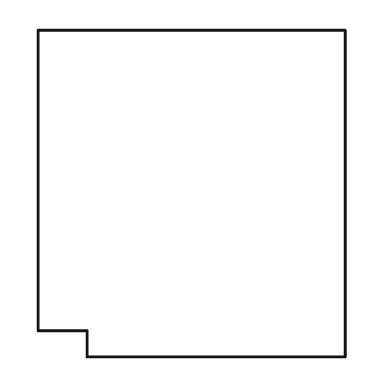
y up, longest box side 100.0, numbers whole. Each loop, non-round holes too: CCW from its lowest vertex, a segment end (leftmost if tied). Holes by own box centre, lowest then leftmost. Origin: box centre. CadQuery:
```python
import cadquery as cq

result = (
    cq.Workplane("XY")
    .moveTo(-32.0, -50.0)
    .lineTo(47.0, -50.0)
    .lineTo(47.0, 50.0)
    .lineTo(-47.0, 50.0)
    .lineTo(-47.0, -42.0)
    .lineTo(-32.0, -42.0)
    .close()
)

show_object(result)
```